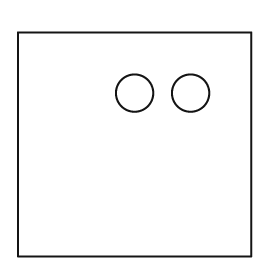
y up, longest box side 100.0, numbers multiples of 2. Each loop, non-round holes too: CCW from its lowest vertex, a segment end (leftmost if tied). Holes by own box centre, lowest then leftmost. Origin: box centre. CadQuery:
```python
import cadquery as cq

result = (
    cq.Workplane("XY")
    .moveTo(-50.0, -48.0)
    .lineTo(50.0, -48.0)
    .lineTo(50.0, 48.0)
    .lineTo(-50.0, 48.0)
    .close()
    .moveTo(0.0, 22.0)
    .circle(8.0)
    .moveTo(24.0, 22.0)
    .circle(8.0)
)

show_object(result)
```